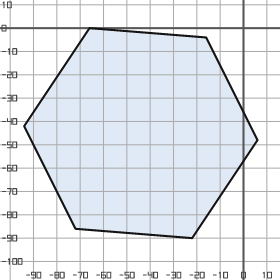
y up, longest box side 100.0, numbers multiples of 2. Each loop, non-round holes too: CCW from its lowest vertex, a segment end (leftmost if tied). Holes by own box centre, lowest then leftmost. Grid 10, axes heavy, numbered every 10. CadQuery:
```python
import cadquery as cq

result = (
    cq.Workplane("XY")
    .moveTo(-22.0, -90.0)
    .lineTo(6.0, -48.0)
    .lineTo(-16.0, -4.0)
    .lineTo(-66.0, 0.0)
    .lineTo(-94.0, -42.0)
    .lineTo(-72.0, -86.0)
    .close()
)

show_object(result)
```